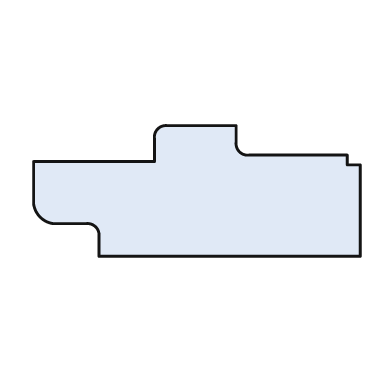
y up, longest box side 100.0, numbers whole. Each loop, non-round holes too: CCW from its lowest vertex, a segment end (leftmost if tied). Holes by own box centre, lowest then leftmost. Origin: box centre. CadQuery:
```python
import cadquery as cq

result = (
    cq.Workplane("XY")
    .moveTo(-30.0, -20.0)
    .lineTo(50.0, -20.0)
    .lineTo(50.0, 8.0)
    .lineTo(46.0, 8.0)
    .lineTo(46.0, 11.0)
    .lineTo(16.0, 11.0)
    .threePointArc((13.0, 12.0), (12.0, 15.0))
    .lineTo(12.0, 20.0)
    .lineTo(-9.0, 20.0)
    .threePointArc((-12.0, 19.0), (-13.0, 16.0))
    .lineTo(-13.0, 9.0)
    .lineTo(-50.0, 9.0)
    .lineTo(-50.0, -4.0)
    .threePointArc((-48.0, -8.0), (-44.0, -10.0))
    .lineTo(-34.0, -10.0)
    .threePointArc((-31.0, -11.0), (-30.0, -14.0))
    .close()
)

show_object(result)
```